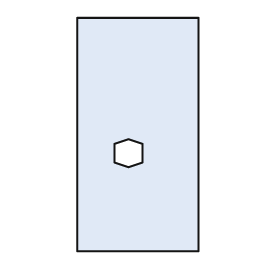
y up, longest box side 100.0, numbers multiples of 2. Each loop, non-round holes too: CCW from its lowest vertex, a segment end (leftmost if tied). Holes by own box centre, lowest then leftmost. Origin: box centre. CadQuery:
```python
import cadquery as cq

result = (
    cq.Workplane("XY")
    .moveTo(-26.0, -50.0)
    .lineTo(26.0, -50.0)
    .lineTo(26.0, 50.0)
    .lineTo(-26.0, 50.0)
    .close()
    .moveTo(-4.0, -14.0)
    .lineTo(2.0, -12.0)
    .lineTo(2.0, -4.0)
    .lineTo(-4.0, -2.0)
    .lineTo(-10.0, -4.0)
    .lineTo(-10.0, -12.0)
    .close()
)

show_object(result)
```